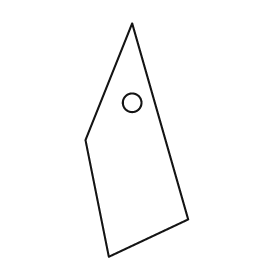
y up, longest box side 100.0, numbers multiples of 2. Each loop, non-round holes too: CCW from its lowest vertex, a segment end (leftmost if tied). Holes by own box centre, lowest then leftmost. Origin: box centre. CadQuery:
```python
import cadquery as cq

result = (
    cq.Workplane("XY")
    .moveTo(-12.0, -50.0)
    .lineTo(22.0, -34.0)
    .lineTo(-2.0, 50.0)
    .lineTo(-22.0, 0.0)
    .close()
    .moveTo(-2.0, 16.0)
    .circle(4.0)
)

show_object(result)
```